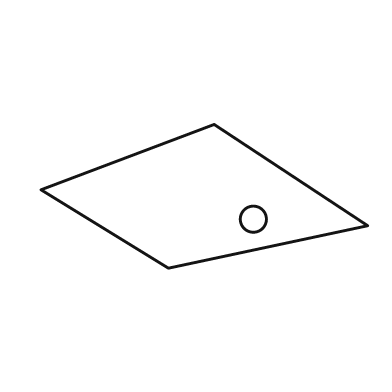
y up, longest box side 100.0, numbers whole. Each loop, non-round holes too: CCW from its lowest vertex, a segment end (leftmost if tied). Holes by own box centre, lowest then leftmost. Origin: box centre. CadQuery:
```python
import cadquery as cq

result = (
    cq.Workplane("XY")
    .moveTo(-11.0, -22.0)
    .lineTo(50.0, -9.0)
    .lineTo(3.0, 22.0)
    .lineTo(-50.0, 2.0)
    .close()
    .moveTo(15.0, -7.0)
    .circle(4.0)
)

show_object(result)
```